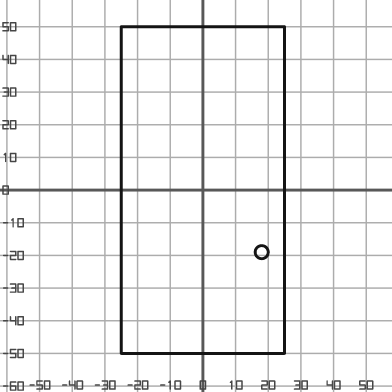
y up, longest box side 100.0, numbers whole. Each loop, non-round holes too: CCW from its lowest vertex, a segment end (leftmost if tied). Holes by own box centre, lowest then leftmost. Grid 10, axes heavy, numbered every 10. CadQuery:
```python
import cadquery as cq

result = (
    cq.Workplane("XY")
    .moveTo(-25.0, -50.0)
    .lineTo(25.0, -50.0)
    .lineTo(25.0, 50.0)
    .lineTo(-25.0, 50.0)
    .close()
    .moveTo(18.0, -19.0)
    .circle(2.0)
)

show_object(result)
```